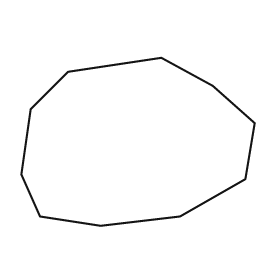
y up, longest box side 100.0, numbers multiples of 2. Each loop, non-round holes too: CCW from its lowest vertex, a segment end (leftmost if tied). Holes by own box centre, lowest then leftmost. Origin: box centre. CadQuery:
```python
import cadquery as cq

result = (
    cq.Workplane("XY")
    .moveTo(-16.0, -36.0)
    .lineTo(18.0, -32.0)
    .lineTo(46.0, -16.0)
    .lineTo(50.0, 8.0)
    .lineTo(32.0, 24.0)
    .lineTo(10.0, 36.0)
    .lineTo(-30.0, 30.0)
    .lineTo(-46.0, 14.0)
    .lineTo(-50.0, -14.0)
    .lineTo(-42.0, -32.0)
    .close()
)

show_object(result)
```